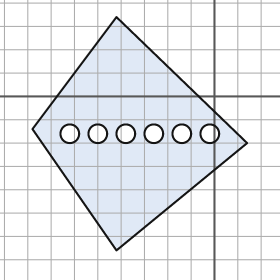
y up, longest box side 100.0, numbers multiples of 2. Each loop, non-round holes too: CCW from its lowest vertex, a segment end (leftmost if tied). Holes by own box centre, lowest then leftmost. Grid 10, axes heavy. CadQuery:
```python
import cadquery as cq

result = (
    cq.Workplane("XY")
    .moveTo(-42.0, -66.0)
    .lineTo(14.0, -20.0)
    .lineTo(-42.0, 34.0)
    .lineTo(-78.0, -14.0)
    .close()
    .moveTo(-62.0, -16.0)
    .circle(4.0)
    .moveTo(-50.0, -16.0)
    .circle(4.0)
    .moveTo(-38.0, -16.0)
    .circle(4.0)
    .moveTo(-26.0, -16.0)
    .circle(4.0)
    .moveTo(-14.0, -16.0)
    .circle(4.0)
    .moveTo(-2.0, -16.0)
    .circle(4.0)
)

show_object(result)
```